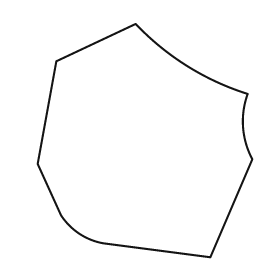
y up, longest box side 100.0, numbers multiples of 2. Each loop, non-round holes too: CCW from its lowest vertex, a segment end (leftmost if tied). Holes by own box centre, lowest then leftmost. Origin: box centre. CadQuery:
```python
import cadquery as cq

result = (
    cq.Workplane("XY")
    .moveTo(28.0, -50.0)
    .lineTo(46.0, -8.0)
    .threePointArc((42.0, 6.0), (44.0, 20.0))
    .threePointArc((18.0, 32.0), (-4.0, 50.0))
    .lineTo(-38.0, 34.0)
    .lineTo(-46.0, -10.0)
    .lineTo(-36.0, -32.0)
    .threePointArc((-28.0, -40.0), (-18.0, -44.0))
    .close()
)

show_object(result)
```